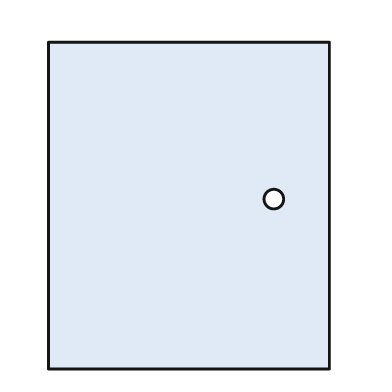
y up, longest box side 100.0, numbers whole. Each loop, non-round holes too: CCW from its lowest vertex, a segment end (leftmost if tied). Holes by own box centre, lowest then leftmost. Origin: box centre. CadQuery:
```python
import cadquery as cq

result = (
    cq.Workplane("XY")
    .moveTo(-43.0, -50.0)
    .lineTo(43.0, -50.0)
    .lineTo(43.0, 50.0)
    .lineTo(-43.0, 50.0)
    .close()
    .moveTo(26.0, 2.0)
    .circle(3.0)
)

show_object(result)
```